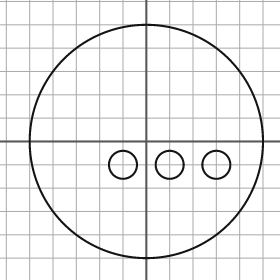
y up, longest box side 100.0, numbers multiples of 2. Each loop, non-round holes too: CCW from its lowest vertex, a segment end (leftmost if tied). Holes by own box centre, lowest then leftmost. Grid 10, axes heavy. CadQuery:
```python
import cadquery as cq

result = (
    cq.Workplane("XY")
    .moveTo(0.0, 0.0)
    .circle(50.0)
    .moveTo(-10.0, -10.0)
    .circle(6.0)
    .moveTo(10.0, -10.0)
    .circle(6.0)
    .moveTo(30.0, -10.0)
    .circle(6.0)
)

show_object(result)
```